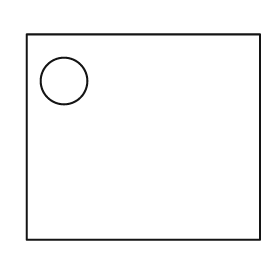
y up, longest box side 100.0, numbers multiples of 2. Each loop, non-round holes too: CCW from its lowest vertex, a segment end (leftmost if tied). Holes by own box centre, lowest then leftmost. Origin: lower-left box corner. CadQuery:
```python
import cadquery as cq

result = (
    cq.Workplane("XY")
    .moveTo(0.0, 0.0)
    .lineTo(100.0, 0.0)
    .lineTo(100.0, 88.0)
    .lineTo(0.0, 88.0)
    .close()
    .moveTo(16.0, 68.0)
    .circle(10.0)
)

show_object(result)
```